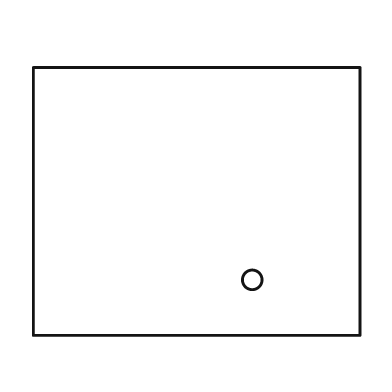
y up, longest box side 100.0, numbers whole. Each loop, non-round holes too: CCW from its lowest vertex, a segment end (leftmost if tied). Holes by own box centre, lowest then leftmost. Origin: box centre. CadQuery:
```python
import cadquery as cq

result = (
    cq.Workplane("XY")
    .moveTo(-50.0, -41.0)
    .lineTo(50.0, -41.0)
    .lineTo(50.0, 41.0)
    .lineTo(-50.0, 41.0)
    .close()
    .moveTo(17.0, -24.0)
    .circle(3.0)
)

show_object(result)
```